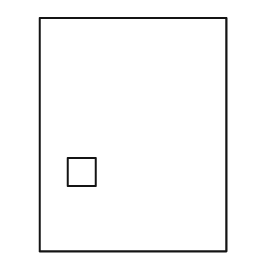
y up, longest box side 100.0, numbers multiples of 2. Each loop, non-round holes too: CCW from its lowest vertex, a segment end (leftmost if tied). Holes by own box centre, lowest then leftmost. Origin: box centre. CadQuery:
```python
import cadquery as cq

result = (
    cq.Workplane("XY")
    .moveTo(-40.0, -50.0)
    .lineTo(40.0, -50.0)
    .lineTo(40.0, 50.0)
    .lineTo(-40.0, 50.0)
    .close()
    .moveTo(-28.0, -22.0)
    .lineTo(-16.0, -22.0)
    .lineTo(-16.0, -10.0)
    .lineTo(-28.0, -10.0)
    .close()
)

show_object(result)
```